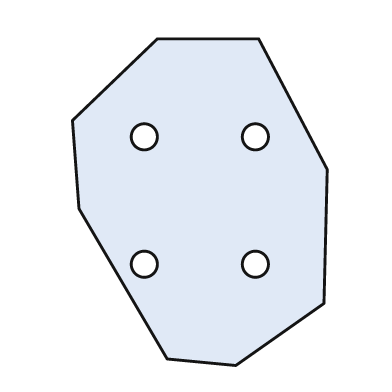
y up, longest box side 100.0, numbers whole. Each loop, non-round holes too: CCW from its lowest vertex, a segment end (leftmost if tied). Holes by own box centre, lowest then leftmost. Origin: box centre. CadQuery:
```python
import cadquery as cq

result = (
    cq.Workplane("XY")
    .moveTo(11.0, -50.0)
    .lineTo(38.0, -31.0)
    .lineTo(39.0, 10.0)
    .lineTo(18.0, 50.0)
    .lineTo(-13.0, 50.0)
    .lineTo(-39.0, 25.0)
    .lineTo(-37.0, -2.0)
    .lineTo(-10.0, -48.0)
    .close()
    .moveTo(-17.0, -19.0)
    .circle(4.0)
    .moveTo(17.0, -19.0)
    .circle(4.0)
    .moveTo(-17.0, 20.0)
    .circle(4.0)
    .moveTo(17.0, 20.0)
    .circle(4.0)
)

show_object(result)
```